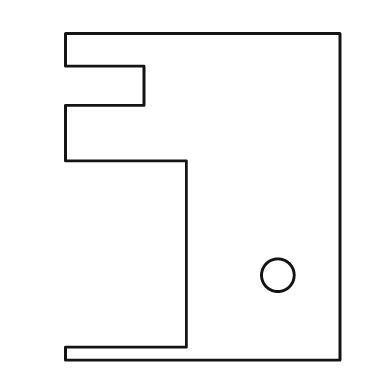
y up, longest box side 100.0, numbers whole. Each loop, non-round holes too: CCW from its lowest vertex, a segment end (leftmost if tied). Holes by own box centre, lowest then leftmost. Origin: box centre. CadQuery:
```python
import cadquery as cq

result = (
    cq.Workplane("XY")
    .moveTo(-42.0, -50.0)
    .lineTo(42.0, -50.0)
    .lineTo(42.0, 50.0)
    .lineTo(-42.0, 50.0)
    .lineTo(-42.0, 40.0)
    .lineTo(-18.0, 40.0)
    .lineTo(-18.0, 28.0)
    .lineTo(-42.0, 28.0)
    .lineTo(-42.0, 11.0)
    .lineTo(-5.0, 11.0)
    .lineTo(-5.0, -46.0)
    .lineTo(-42.0, -46.0)
    .close()
    .moveTo(23.0, -24.0)
    .circle(5.0)
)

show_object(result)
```